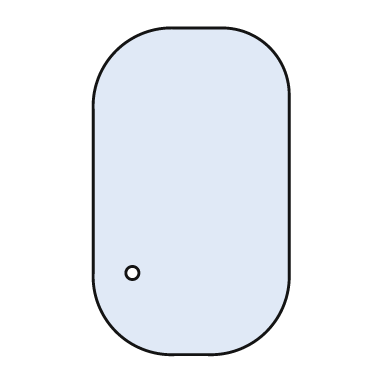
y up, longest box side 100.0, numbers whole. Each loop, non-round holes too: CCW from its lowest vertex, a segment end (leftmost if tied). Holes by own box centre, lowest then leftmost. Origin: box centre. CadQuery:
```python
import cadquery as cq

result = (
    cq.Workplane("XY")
    .moveTo(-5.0, -50.0)
    .lineTo(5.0, -50.0)
    .threePointArc((23.0, -43.0), (30.0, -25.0))
    .lineTo(30.0, 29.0)
    .threePointArc((24.0, 44.0), (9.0, 50.0))
    .lineTo(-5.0, 50.0)
    .threePointArc((-23.0, 43.0), (-30.0, 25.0))
    .lineTo(-30.0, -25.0)
    .threePointArc((-23.0, -43.0), (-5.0, -50.0))
    .close()
    .moveTo(-18.0, -25.0)
    .circle(2.0)
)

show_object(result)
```